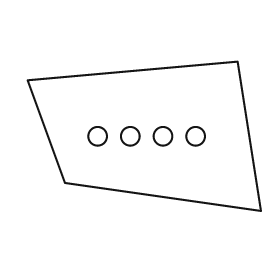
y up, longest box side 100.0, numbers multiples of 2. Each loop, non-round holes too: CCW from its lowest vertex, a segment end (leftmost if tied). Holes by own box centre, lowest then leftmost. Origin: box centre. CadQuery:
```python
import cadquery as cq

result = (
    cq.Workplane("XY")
    .moveTo(50.0, -32.0)
    .lineTo(40.0, 32.0)
    .lineTo(-50.0, 24.0)
    .lineTo(-34.0, -20.0)
    .close()
    .moveTo(-20.0, 0.0)
    .circle(4.0)
    .moveTo(-6.0, 0.0)
    .circle(4.0)
    .moveTo(8.0, 0.0)
    .circle(4.0)
    .moveTo(22.0, 0.0)
    .circle(4.0)
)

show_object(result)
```